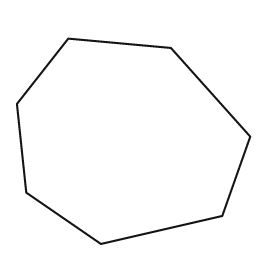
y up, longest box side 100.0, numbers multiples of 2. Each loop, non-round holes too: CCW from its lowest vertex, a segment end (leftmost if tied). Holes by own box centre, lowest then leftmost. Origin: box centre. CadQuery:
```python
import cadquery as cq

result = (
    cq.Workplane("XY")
    .moveTo(-14.0, -44.0)
    .lineTo(38.0, -32.0)
    .lineTo(50.0, 2.0)
    .lineTo(16.0, 40.0)
    .lineTo(-28.0, 44.0)
    .lineTo(-50.0, 16.0)
    .lineTo(-46.0, -22.0)
    .close()
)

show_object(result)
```